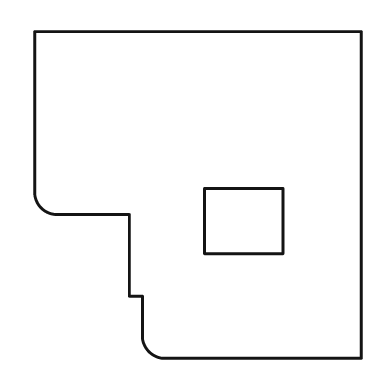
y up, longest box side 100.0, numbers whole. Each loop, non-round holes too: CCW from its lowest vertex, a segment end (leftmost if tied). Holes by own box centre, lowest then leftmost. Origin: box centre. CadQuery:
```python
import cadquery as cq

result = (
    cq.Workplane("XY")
    .moveTo(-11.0, -50.0)
    .lineTo(50.0, -50.0)
    .lineTo(50.0, 50.0)
    .lineTo(-50.0, 50.0)
    .lineTo(-50.0, 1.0)
    .threePointArc((-48.0, -4.0), (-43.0, -6.0))
    .lineTo(-21.0, -6.0)
    .lineTo(-21.0, -31.0)
    .lineTo(-17.0, -31.0)
    .lineTo(-17.0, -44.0)
    .threePointArc((-15.0, -48.0), (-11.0, -50.0))
    .close()
    .moveTo(2.0, -18.0)
    .lineTo(26.0, -18.0)
    .lineTo(26.0, 2.0)
    .lineTo(2.0, 2.0)
    .close()
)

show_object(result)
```